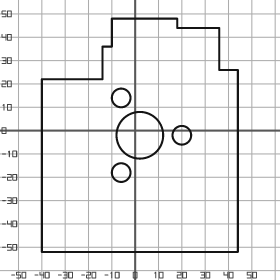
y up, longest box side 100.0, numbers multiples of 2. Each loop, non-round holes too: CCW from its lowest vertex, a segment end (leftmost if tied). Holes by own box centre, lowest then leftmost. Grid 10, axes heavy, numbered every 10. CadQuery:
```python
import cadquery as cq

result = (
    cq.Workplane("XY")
    .moveTo(-40.0, -52.0)
    .lineTo(44.0, -52.0)
    .lineTo(44.0, 26.0)
    .lineTo(36.0, 26.0)
    .lineTo(36.0, 44.0)
    .lineTo(18.0, 44.0)
    .lineTo(18.0, 48.0)
    .lineTo(-10.0, 48.0)
    .lineTo(-10.0, 36.0)
    .lineTo(-14.0, 36.0)
    .lineTo(-14.0, 22.0)
    .lineTo(-40.0, 22.0)
    .close()
    .moveTo(-6.0, -18.0)
    .circle(4.0)
    .moveTo(2.0, -2.0)
    .circle(10.0)
    .moveTo(20.0, -2.0)
    .circle(4.0)
    .moveTo(-6.0, 14.0)
    .circle(4.0)
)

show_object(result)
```